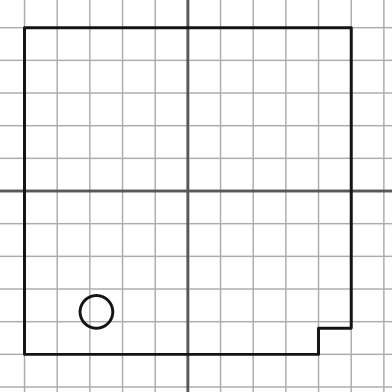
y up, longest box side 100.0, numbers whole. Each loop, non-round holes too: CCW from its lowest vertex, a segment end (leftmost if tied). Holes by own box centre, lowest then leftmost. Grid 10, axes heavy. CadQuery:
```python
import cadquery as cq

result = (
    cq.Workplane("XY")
    .moveTo(-50.0, -50.0)
    .lineTo(40.0, -50.0)
    .lineTo(40.0, -42.0)
    .lineTo(50.0, -42.0)
    .lineTo(50.0, 50.0)
    .lineTo(-50.0, 50.0)
    .close()
    .moveTo(-28.0, -37.0)
    .circle(5.0)
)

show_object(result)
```